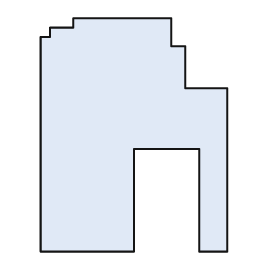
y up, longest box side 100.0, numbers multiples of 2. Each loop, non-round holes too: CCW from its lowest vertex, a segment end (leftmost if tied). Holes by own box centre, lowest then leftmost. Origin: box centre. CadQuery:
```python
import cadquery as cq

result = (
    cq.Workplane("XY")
    .moveTo(-40.0, -50.0)
    .lineTo(0.0, -50.0)
    .lineTo(0.0, -6.0)
    .lineTo(28.0, -6.0)
    .lineTo(28.0, -50.0)
    .lineTo(40.0, -50.0)
    .lineTo(40.0, 20.0)
    .lineTo(22.0, 20.0)
    .lineTo(22.0, 38.0)
    .lineTo(16.0, 38.0)
    .lineTo(16.0, 50.0)
    .lineTo(-26.0, 50.0)
    .lineTo(-26.0, 46.0)
    .lineTo(-36.0, 46.0)
    .lineTo(-36.0, 42.0)
    .lineTo(-40.0, 42.0)
    .close()
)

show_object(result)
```